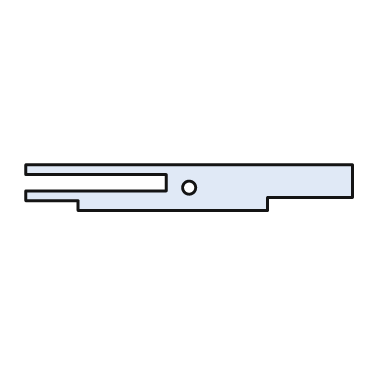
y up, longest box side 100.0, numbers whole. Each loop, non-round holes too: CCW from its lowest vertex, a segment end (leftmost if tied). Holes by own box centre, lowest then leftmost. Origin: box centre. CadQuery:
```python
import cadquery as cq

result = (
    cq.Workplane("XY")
    .moveTo(-34.0, -7.0)
    .lineTo(24.0, -7.0)
    .lineTo(24.0, -3.0)
    .lineTo(50.0, -3.0)
    .lineTo(50.0, 7.0)
    .lineTo(-50.0, 7.0)
    .lineTo(-50.0, 4.0)
    .lineTo(-7.0, 4.0)
    .lineTo(-7.0, -1.0)
    .lineTo(-50.0, -1.0)
    .lineTo(-50.0, -4.0)
    .lineTo(-34.0, -4.0)
    .close()
    .moveTo(0.0, 0.0)
    .circle(2.0)
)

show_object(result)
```